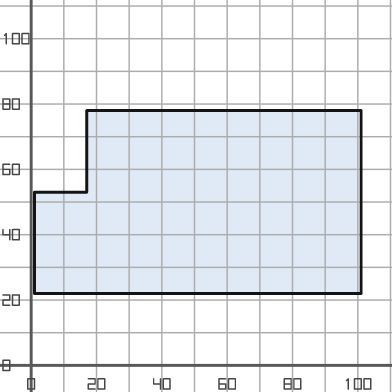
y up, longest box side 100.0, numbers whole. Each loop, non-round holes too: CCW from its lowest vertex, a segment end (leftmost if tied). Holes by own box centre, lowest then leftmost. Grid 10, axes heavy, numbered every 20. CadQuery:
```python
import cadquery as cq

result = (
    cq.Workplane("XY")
    .moveTo(1.0, 22.0)
    .lineTo(101.0, 22.0)
    .lineTo(101.0, 78.0)
    .lineTo(17.0, 78.0)
    .lineTo(17.0, 53.0)
    .lineTo(1.0, 53.0)
    .close()
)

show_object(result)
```